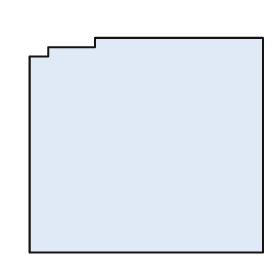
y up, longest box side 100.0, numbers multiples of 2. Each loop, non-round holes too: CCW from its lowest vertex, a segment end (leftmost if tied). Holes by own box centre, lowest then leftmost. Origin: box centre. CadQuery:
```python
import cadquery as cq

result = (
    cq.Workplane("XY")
    .moveTo(-50.0, -46.0)
    .lineTo(50.0, -46.0)
    .lineTo(50.0, 46.0)
    .lineTo(-22.0, 46.0)
    .lineTo(-22.0, 42.0)
    .lineTo(-42.0, 42.0)
    .lineTo(-42.0, 38.0)
    .lineTo(-50.0, 38.0)
    .close()
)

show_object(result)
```